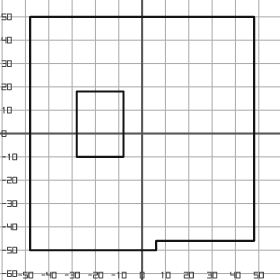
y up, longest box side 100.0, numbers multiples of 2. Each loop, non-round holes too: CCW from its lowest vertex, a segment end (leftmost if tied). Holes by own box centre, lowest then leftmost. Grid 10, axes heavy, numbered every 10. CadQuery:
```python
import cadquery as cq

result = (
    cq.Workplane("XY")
    .moveTo(-48.0, -50.0)
    .lineTo(6.0, -50.0)
    .lineTo(6.0, -46.0)
    .lineTo(48.0, -46.0)
    .lineTo(48.0, 50.0)
    .lineTo(-48.0, 50.0)
    .close()
    .moveTo(-28.0, -10.0)
    .lineTo(-8.0, -10.0)
    .lineTo(-8.0, 18.0)
    .lineTo(-28.0, 18.0)
    .close()
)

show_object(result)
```